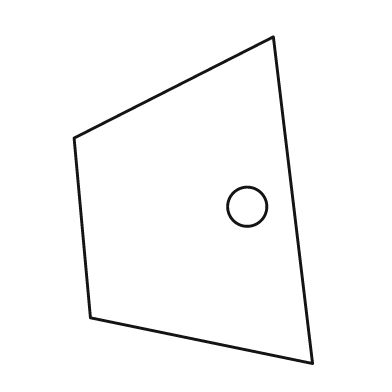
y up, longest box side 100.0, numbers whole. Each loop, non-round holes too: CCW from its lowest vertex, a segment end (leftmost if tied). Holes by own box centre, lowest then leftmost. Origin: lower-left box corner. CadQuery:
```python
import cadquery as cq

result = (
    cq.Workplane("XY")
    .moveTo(73.0, 0.0)
    .lineTo(61.0, 100.0)
    .lineTo(0.0, 69.0)
    .lineTo(5.0, 14.0)
    .close()
    .moveTo(53.0, 48.0)
    .circle(6.0)
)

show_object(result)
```